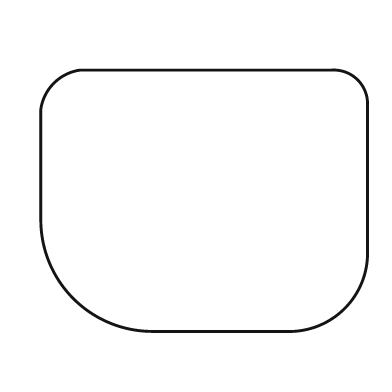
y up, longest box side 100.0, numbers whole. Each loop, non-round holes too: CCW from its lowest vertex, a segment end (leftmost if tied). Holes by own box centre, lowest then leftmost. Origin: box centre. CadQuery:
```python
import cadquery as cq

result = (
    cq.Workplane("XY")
    .moveTo(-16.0, -40.0)
    .lineTo(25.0, -40.0)
    .threePointArc((43.0, -33.0), (50.0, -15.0))
    .lineTo(50.0, 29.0)
    .threePointArc((47.0, 37.0), (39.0, 40.0))
    .lineTo(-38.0, 40.0)
    .threePointArc((-46.0, 36.0), (-50.0, 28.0))
    .lineTo(-50.0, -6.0)
    .threePointArc((-40.0, -30.0), (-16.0, -40.0))
    .close()
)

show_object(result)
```